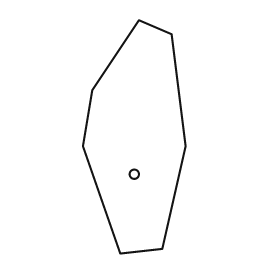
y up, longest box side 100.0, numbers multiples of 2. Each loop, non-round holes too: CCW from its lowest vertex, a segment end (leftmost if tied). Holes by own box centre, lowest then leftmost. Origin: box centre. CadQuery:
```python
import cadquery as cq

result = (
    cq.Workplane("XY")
    .moveTo(-6.0, -50.0)
    .lineTo(12.0, -48.0)
    .lineTo(22.0, -4.0)
    .lineTo(16.0, 44.0)
    .lineTo(2.0, 50.0)
    .lineTo(-18.0, 20.0)
    .lineTo(-22.0, -4.0)
    .close()
    .moveTo(0.0, -16.0)
    .circle(2.0)
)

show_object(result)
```